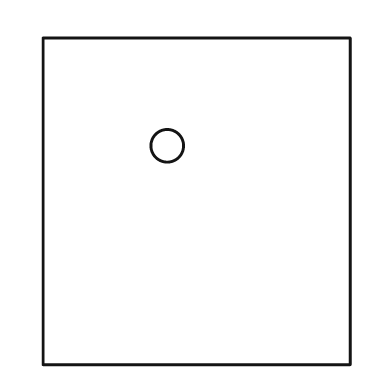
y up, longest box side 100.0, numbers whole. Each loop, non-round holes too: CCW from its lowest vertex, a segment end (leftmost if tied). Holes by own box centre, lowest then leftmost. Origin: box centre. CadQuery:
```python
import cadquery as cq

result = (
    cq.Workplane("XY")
    .moveTo(-47.0, -50.0)
    .lineTo(47.0, -50.0)
    .lineTo(47.0, 50.0)
    .lineTo(-47.0, 50.0)
    .close()
    .moveTo(-9.0, 17.0)
    .circle(5.0)
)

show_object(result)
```